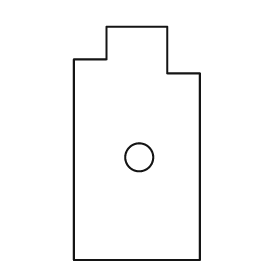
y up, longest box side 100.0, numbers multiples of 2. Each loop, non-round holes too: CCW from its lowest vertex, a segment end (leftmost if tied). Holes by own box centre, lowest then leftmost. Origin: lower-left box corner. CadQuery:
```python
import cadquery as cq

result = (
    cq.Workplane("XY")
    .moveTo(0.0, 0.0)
    .lineTo(54.0, 0.0)
    .lineTo(54.0, 80.0)
    .lineTo(40.0, 80.0)
    .lineTo(40.0, 100.0)
    .lineTo(14.0, 100.0)
    .lineTo(14.0, 86.0)
    .lineTo(0.0, 86.0)
    .close()
    .moveTo(28.0, 44.0)
    .circle(6.0)
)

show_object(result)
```